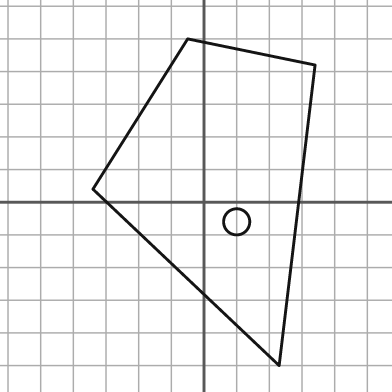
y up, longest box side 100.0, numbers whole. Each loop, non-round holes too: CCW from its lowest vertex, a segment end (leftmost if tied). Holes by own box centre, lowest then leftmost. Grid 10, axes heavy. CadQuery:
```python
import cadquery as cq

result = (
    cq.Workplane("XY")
    .moveTo(23.0, -50.0)
    .lineTo(34.0, 42.0)
    .lineTo(-5.0, 50.0)
    .lineTo(-34.0, 4.0)
    .close()
    .moveTo(10.0, -6.0)
    .circle(4.0)
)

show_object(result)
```